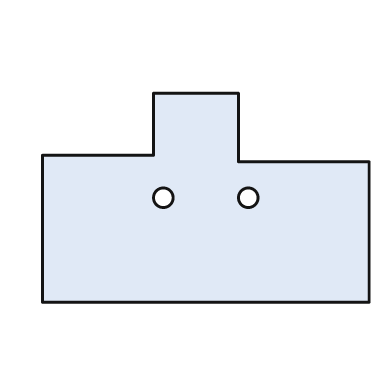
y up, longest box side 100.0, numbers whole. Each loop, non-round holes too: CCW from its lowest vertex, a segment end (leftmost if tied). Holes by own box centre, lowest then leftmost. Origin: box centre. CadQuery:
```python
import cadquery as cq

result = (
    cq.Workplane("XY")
    .moveTo(-50.0, -32.0)
    .lineTo(50.0, -32.0)
    .lineTo(50.0, 11.0)
    .lineTo(10.0, 11.0)
    .lineTo(10.0, 32.0)
    .lineTo(-16.0, 32.0)
    .lineTo(-16.0, 13.0)
    .lineTo(-50.0, 13.0)
    .close()
    .moveTo(-13.0, 0.0)
    .circle(3.0)
    .moveTo(13.0, 0.0)
    .circle(3.0)
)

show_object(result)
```